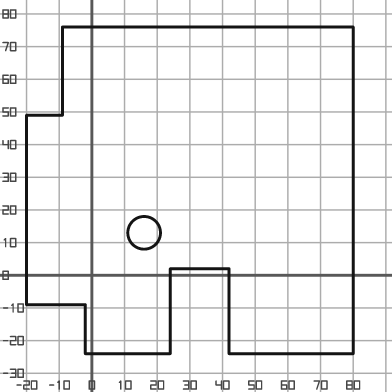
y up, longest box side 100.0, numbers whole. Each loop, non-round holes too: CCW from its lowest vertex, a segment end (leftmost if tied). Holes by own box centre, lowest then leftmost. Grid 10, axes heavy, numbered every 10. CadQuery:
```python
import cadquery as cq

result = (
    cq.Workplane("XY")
    .moveTo(-2.0, -24.0)
    .lineTo(24.0, -24.0)
    .lineTo(24.0, 2.0)
    .lineTo(42.0, 2.0)
    .lineTo(42.0, -24.0)
    .lineTo(80.0, -24.0)
    .lineTo(80.0, 76.0)
    .lineTo(-9.0, 76.0)
    .lineTo(-9.0, 49.0)
    .lineTo(-20.0, 49.0)
    .lineTo(-20.0, -9.0)
    .lineTo(-2.0, -9.0)
    .close()
    .moveTo(16.0, 13.0)
    .circle(5.0)
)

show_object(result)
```